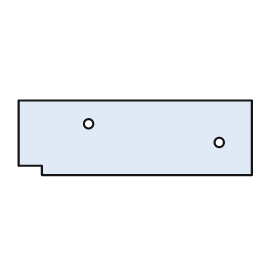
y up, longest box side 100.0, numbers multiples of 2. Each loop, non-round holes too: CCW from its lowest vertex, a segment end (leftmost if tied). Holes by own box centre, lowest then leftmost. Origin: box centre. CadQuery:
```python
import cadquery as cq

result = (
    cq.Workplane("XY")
    .moveTo(-40.0, -16.0)
    .lineTo(50.0, -16.0)
    .lineTo(50.0, 16.0)
    .lineTo(-50.0, 16.0)
    .lineTo(-50.0, -12.0)
    .lineTo(-40.0, -12.0)
    .close()
    .moveTo(36.0, -2.0)
    .circle(2.0)
    .moveTo(-20.0, 6.0)
    .circle(2.0)
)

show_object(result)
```